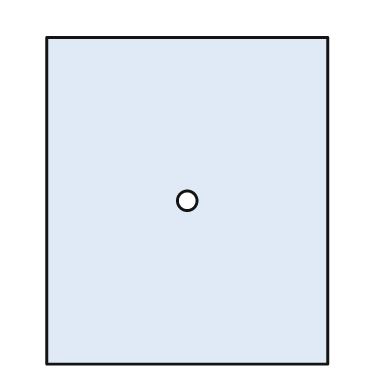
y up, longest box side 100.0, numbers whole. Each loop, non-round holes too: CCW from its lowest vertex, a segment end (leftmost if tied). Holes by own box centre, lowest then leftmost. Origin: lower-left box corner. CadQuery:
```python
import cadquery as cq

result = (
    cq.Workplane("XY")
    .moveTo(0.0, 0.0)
    .lineTo(86.0, 0.0)
    .lineTo(86.0, 100.0)
    .lineTo(0.0, 100.0)
    .close()
    .moveTo(43.0, 50.0)
    .circle(3.0)
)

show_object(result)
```